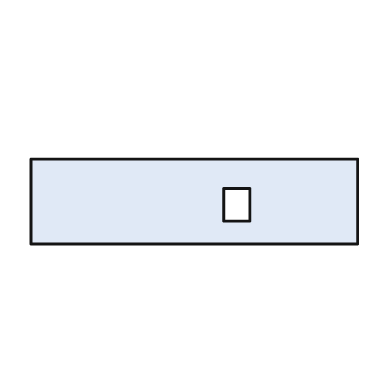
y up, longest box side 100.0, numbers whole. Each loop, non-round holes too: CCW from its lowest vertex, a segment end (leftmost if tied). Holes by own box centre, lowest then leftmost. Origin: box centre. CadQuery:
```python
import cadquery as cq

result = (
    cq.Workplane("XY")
    .moveTo(-50.0, -13.0)
    .lineTo(50.0, -13.0)
    .lineTo(50.0, 13.0)
    .lineTo(-50.0, 13.0)
    .close()
    .moveTo(9.0, -6.0)
    .lineTo(17.0, -6.0)
    .lineTo(17.0, 4.0)
    .lineTo(9.0, 4.0)
    .close()
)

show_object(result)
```